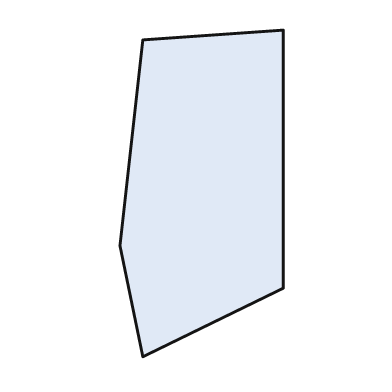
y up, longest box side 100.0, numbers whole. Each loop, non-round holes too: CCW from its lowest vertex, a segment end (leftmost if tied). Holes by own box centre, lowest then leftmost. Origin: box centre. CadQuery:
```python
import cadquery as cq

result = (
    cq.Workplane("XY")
    .moveTo(-18.0, -50.0)
    .lineTo(25.0, -29.0)
    .lineTo(25.0, 50.0)
    .lineTo(-18.0, 47.0)
    .lineTo(-25.0, -16.0)
    .close()
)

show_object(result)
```